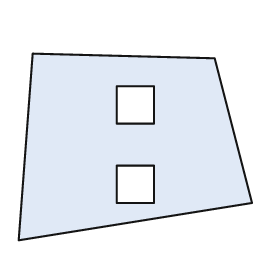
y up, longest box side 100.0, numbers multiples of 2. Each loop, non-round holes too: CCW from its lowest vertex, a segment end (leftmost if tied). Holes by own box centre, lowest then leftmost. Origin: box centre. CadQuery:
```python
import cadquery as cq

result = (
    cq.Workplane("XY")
    .moveTo(-50.0, -40.0)
    .lineTo(50.0, -24.0)
    .lineTo(34.0, 38.0)
    .lineTo(-44.0, 40.0)
    .close()
    .moveTo(-8.0, -24.0)
    .lineTo(8.0, -24.0)
    .lineTo(8.0, -8.0)
    .lineTo(-8.0, -8.0)
    .close()
    .moveTo(-8.0, 10.0)
    .lineTo(8.0, 10.0)
    .lineTo(8.0, 26.0)
    .lineTo(-8.0, 26.0)
    .close()
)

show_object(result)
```